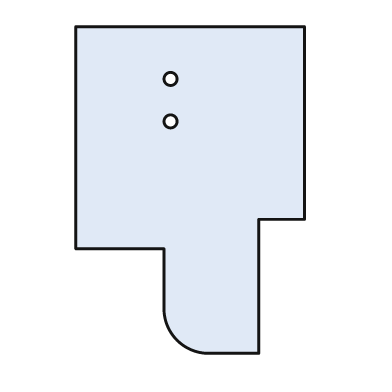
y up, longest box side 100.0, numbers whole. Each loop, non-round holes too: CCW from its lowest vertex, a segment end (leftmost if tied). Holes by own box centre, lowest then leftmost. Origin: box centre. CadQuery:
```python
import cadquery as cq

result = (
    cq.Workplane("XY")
    .moveTo(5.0, -50.0)
    .lineTo(21.0, -50.0)
    .lineTo(21.0, -9.0)
    .lineTo(35.0, -9.0)
    .lineTo(35.0, 50.0)
    .lineTo(-35.0, 50.0)
    .lineTo(-35.0, -18.0)
    .lineTo(-8.0, -18.0)
    .lineTo(-8.0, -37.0)
    .threePointArc((-4.0, -46.0), (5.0, -50.0))
    .close()
    .moveTo(-6.0, 21.0)
    .circle(2.0)
    .moveTo(-6.0, 34.0)
    .circle(2.0)
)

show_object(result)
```